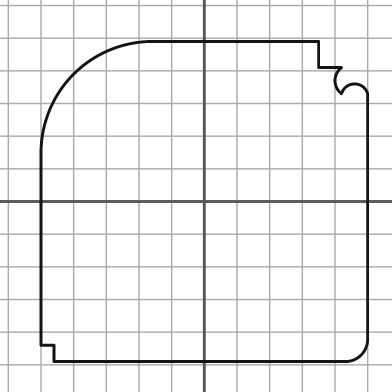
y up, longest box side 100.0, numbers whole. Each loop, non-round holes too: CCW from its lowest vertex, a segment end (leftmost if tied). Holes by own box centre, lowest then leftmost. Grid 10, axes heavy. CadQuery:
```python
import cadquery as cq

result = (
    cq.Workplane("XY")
    .moveTo(-46.0, -49.0)
    .lineTo(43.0, -49.0)
    .threePointArc((48.0, -47.0), (50.0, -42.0))
    .lineTo(50.0, 33.0)
    .threePointArc((46.0, 36.0), (42.0, 33.0))
    .threePointArc((40.0, 37.0), (42.0, 41.0))
    .lineTo(35.0, 41.0)
    .lineTo(35.0, 49.0)
    .lineTo(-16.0, 49.0)
    .threePointArc((-40.0, 39.0), (-50.0, 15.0))
    .lineTo(-50.0, -44.0)
    .lineTo(-46.0, -44.0)
    .close()
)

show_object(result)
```